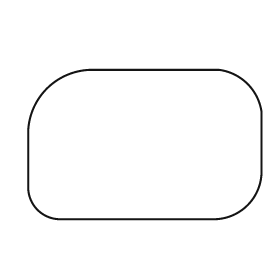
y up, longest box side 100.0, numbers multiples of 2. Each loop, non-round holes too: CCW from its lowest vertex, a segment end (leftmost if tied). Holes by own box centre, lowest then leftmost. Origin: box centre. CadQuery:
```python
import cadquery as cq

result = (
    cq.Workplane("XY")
    .moveTo(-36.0, -32.0)
    .lineTo(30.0, -32.0)
    .threePointArc((44.0, -26.0), (50.0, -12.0))
    .lineTo(50.0, 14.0)
    .threePointArc((44.0, 26.0), (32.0, 32.0))
    .lineTo(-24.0, 32.0)
    .threePointArc((-42.0, 24.0), (-50.0, 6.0))
    .lineTo(-50.0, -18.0)
    .threePointArc((-46.0, -28.0), (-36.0, -32.0))
    .close()
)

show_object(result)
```